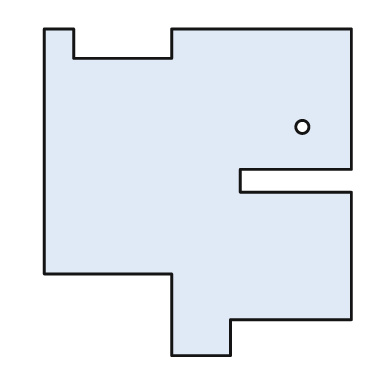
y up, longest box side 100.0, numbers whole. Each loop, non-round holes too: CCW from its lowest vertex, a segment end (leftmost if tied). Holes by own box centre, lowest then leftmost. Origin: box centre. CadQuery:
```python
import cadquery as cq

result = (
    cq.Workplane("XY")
    .moveTo(-8.0, -50.0)
    .lineTo(10.0, -50.0)
    .lineTo(10.0, -39.0)
    .lineTo(47.0, -39.0)
    .lineTo(47.0, 0.0)
    .lineTo(13.0, 0.0)
    .lineTo(13.0, 7.0)
    .lineTo(47.0, 7.0)
    .lineTo(47.0, 50.0)
    .lineTo(-8.0, 50.0)
    .lineTo(-8.0, 41.0)
    .lineTo(-38.0, 41.0)
    .lineTo(-38.0, 50.0)
    .lineTo(-47.0, 50.0)
    .lineTo(-47.0, -25.0)
    .lineTo(-8.0, -25.0)
    .close()
    .moveTo(32.0, 20.0)
    .circle(2.0)
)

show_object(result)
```